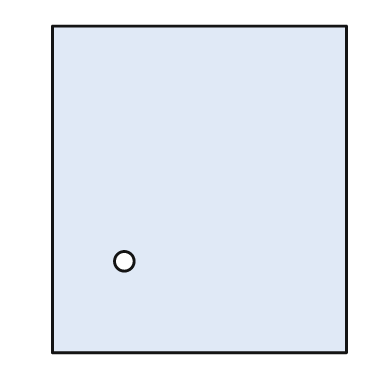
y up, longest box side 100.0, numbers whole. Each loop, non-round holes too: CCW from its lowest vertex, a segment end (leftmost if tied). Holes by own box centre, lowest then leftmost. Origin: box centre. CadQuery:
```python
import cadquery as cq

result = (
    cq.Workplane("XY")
    .moveTo(-45.0, -50.0)
    .lineTo(45.0, -50.0)
    .lineTo(45.0, 50.0)
    .lineTo(-45.0, 50.0)
    .close()
    .moveTo(-23.0, -22.0)
    .circle(3.0)
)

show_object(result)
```